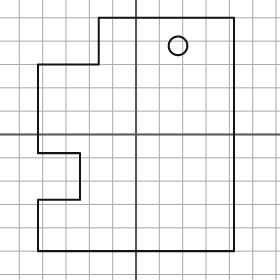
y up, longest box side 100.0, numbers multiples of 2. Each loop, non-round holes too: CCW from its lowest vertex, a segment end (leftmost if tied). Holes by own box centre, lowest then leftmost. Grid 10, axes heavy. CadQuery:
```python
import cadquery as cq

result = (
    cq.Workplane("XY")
    .moveTo(-42.0, -50.0)
    .lineTo(42.0, -50.0)
    .lineTo(42.0, 50.0)
    .lineTo(-16.0, 50.0)
    .lineTo(-16.0, 30.0)
    .lineTo(-42.0, 30.0)
    .lineTo(-42.0, -8.0)
    .lineTo(-24.0, -8.0)
    .lineTo(-24.0, -28.0)
    .lineTo(-42.0, -28.0)
    .close()
    .moveTo(18.0, 38.0)
    .circle(4.0)
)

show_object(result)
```